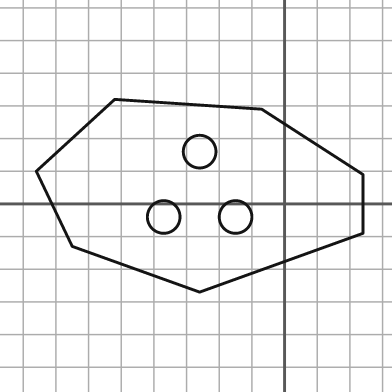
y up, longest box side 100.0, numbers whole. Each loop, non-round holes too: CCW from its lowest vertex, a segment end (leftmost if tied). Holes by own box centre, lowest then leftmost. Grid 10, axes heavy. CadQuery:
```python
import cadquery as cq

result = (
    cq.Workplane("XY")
    .moveTo(-26.0, -27.0)
    .lineTo(24.0, -9.0)
    .lineTo(24.0, 9.0)
    .lineTo(-7.0, 29.0)
    .lineTo(-52.0, 32.0)
    .lineTo(-76.0, 10.0)
    .lineTo(-65.0, -13.0)
    .close()
    .moveTo(-37.0, -4.0)
    .circle(5.0)
    .moveTo(-15.0, -4.0)
    .circle(5.0)
    .moveTo(-26.0, 16.0)
    .circle(5.0)
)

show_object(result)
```